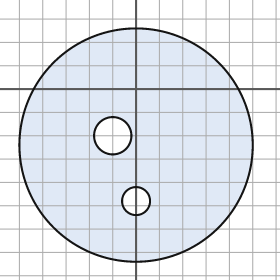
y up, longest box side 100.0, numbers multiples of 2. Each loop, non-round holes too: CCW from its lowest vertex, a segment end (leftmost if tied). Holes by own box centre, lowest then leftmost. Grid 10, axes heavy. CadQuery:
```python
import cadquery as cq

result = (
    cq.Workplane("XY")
    .moveTo(0.0, -24.0)
    .circle(50.0)
    .moveTo(0.0, -48.0)
    .circle(6.0)
    .moveTo(-10.0, -20.0)
    .circle(8.0)
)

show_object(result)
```